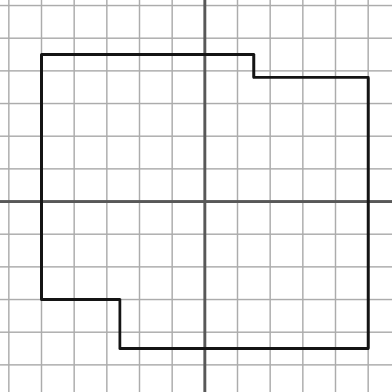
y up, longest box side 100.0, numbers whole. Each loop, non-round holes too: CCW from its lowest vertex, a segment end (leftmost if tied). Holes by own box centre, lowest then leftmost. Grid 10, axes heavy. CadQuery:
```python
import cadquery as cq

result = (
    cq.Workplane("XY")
    .moveTo(-26.0, -45.0)
    .lineTo(50.0, -45.0)
    .lineTo(50.0, 38.0)
    .lineTo(15.0, 38.0)
    .lineTo(15.0, 45.0)
    .lineTo(-50.0, 45.0)
    .lineTo(-50.0, -30.0)
    .lineTo(-26.0, -30.0)
    .close()
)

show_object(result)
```